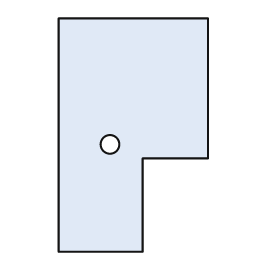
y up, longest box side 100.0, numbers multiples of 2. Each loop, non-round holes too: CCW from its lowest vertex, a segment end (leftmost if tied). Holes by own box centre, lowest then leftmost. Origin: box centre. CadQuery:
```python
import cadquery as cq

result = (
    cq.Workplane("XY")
    .moveTo(-32.0, -50.0)
    .lineTo(4.0, -50.0)
    .lineTo(4.0, -10.0)
    .lineTo(32.0, -10.0)
    .lineTo(32.0, 50.0)
    .lineTo(-32.0, 50.0)
    .close()
    .moveTo(-10.0, -4.0)
    .circle(4.0)
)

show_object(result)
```